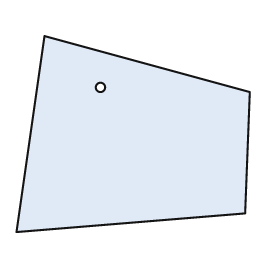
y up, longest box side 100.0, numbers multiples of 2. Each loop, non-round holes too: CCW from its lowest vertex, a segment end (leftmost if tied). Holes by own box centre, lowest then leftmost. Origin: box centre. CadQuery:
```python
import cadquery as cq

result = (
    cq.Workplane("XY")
    .moveTo(-50.0, -42.0)
    .lineTo(48.0, -34.0)
    .lineTo(50.0, 18.0)
    .lineTo(-38.0, 42.0)
    .close()
    .moveTo(-14.0, 20.0)
    .circle(2.0)
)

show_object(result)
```